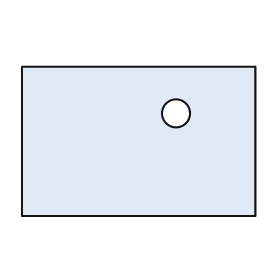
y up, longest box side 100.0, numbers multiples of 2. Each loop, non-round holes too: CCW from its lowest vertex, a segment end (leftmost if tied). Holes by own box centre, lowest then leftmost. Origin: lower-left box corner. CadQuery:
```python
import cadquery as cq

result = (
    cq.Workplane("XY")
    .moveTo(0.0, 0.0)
    .lineTo(100.0, 0.0)
    .lineTo(100.0, 64.0)
    .lineTo(0.0, 64.0)
    .close()
    .moveTo(66.0, 44.0)
    .circle(6.0)
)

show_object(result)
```